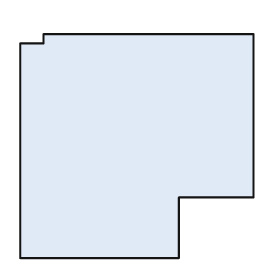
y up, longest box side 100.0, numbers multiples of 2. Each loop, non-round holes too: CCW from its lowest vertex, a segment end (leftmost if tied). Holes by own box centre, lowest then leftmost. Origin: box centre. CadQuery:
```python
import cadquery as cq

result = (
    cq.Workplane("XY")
    .moveTo(-50.0, -48.0)
    .lineTo(18.0, -48.0)
    .lineTo(18.0, -22.0)
    .lineTo(50.0, -22.0)
    .lineTo(50.0, 48.0)
    .lineTo(-40.0, 48.0)
    .lineTo(-40.0, 44.0)
    .lineTo(-50.0, 44.0)
    .close()
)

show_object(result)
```